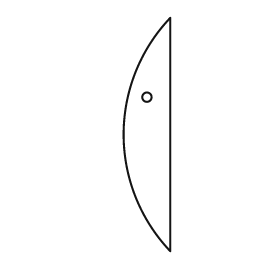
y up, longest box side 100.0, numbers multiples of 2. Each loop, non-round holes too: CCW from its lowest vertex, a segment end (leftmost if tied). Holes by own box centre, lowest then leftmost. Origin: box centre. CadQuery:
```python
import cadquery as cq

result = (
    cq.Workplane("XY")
    .moveTo(10.0, -50.0)
    .lineTo(10.0, 50.0)
    .threePointArc((-10.0, 0.0), (10.0, -50.0))
    .close()
    .moveTo(0.0, 16.0)
    .circle(2.0)
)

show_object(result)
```